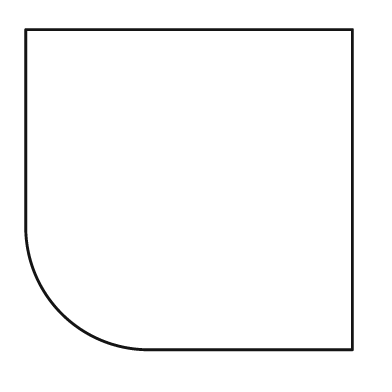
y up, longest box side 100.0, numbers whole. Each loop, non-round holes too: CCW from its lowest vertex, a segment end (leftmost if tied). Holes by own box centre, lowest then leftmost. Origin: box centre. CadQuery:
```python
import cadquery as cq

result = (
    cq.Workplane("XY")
    .moveTo(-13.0, -49.0)
    .lineTo(50.0, -49.0)
    .lineTo(50.0, 49.0)
    .lineTo(-50.0, 49.0)
    .lineTo(-50.0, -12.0)
    .threePointArc((-39.0, -38.0), (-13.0, -49.0))
    .close()
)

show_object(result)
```